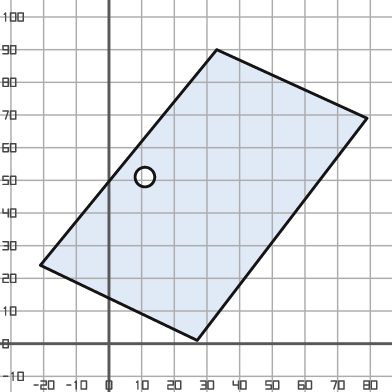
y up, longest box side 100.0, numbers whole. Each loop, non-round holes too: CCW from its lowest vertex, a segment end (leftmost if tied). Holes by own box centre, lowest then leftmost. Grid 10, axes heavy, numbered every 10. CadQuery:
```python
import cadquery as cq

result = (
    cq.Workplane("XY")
    .moveTo(27.0, 1.0)
    .lineTo(79.0, 69.0)
    .lineTo(33.0, 90.0)
    .lineTo(-21.0, 24.0)
    .close()
    .moveTo(11.0, 51.0)
    .circle(3.0)
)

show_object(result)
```